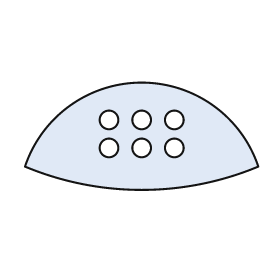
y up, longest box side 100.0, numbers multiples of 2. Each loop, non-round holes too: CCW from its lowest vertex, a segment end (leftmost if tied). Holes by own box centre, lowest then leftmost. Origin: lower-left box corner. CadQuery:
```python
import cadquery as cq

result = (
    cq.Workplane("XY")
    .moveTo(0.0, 10.0)
    .threePointArc((50.0, 0.0), (100.0, 10.0))
    .threePointArc((50.0, 46.0), (0.0, 10.0))
    .close()
    .moveTo(36.0, 18.0)
    .circle(4.0)
    .moveTo(50.0, 18.0)
    .circle(4.0)
    .moveTo(64.0, 18.0)
    .circle(4.0)
    .moveTo(36.0, 30.0)
    .circle(4.0)
    .moveTo(50.0, 30.0)
    .circle(4.0)
    .moveTo(64.0, 30.0)
    .circle(4.0)
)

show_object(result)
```